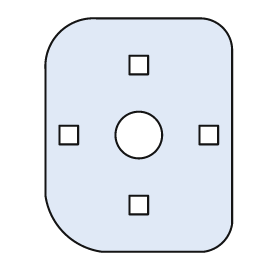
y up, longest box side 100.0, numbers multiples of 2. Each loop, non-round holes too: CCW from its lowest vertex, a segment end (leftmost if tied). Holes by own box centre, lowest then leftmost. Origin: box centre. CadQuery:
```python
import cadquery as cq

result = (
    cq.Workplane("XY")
    .moveTo(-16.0, -50.0)
    .lineTo(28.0, -50.0)
    .threePointArc((36.0, -46.0), (40.0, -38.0))
    .lineTo(40.0, 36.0)
    .threePointArc((36.0, 46.0), (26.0, 50.0))
    .lineTo(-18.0, 50.0)
    .threePointArc((-34.0, 44.0), (-40.0, 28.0))
    .lineTo(-40.0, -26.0)
    .threePointArc((-32.0, -42.0), (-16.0, -50.0))
    .close()
    .moveTo(-4.0, -34.0)
    .lineTo(4.0, -34.0)
    .lineTo(4.0, -26.0)
    .lineTo(-4.0, -26.0)
    .close()
    .moveTo(-34.0, -4.0)
    .lineTo(-26.0, -4.0)
    .lineTo(-26.0, 4.0)
    .lineTo(-34.0, 4.0)
    .close()
    .moveTo(0.0, 0.0)
    .circle(10.0)
    .moveTo(26.0, -4.0)
    .lineTo(34.0, -4.0)
    .lineTo(34.0, 4.0)
    .lineTo(26.0, 4.0)
    .close()
    .moveTo(-4.0, 26.0)
    .lineTo(4.0, 26.0)
    .lineTo(4.0, 34.0)
    .lineTo(-4.0, 34.0)
    .close()
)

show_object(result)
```